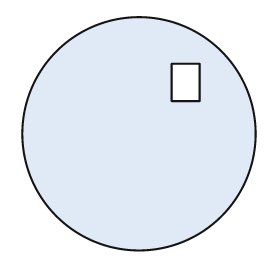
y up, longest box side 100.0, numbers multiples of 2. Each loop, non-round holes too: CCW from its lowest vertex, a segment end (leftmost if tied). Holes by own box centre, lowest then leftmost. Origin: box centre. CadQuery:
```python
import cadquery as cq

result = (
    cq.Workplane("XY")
    .moveTo(0.0, 0.0)
    .circle(50.0)
    .moveTo(14.0, 14.0)
    .lineTo(26.0, 14.0)
    .lineTo(26.0, 30.0)
    .lineTo(14.0, 30.0)
    .close()
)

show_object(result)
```